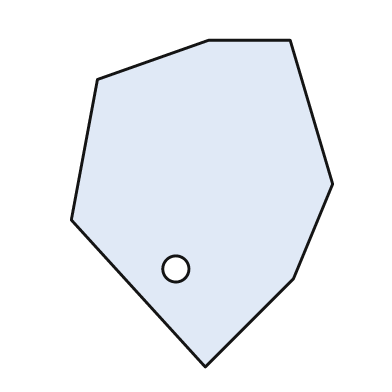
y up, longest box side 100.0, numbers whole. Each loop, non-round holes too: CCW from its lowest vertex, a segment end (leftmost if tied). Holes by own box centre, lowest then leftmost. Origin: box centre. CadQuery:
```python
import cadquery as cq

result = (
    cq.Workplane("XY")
    .moveTo(1.0, -50.0)
    .lineTo(28.0, -23.0)
    .lineTo(40.0, 6.0)
    .lineTo(27.0, 50.0)
    .lineTo(2.0, 50.0)
    .lineTo(-32.0, 38.0)
    .lineTo(-40.0, -5.0)
    .close()
    .moveTo(-8.0, -20.0)
    .circle(4.0)
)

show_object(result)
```